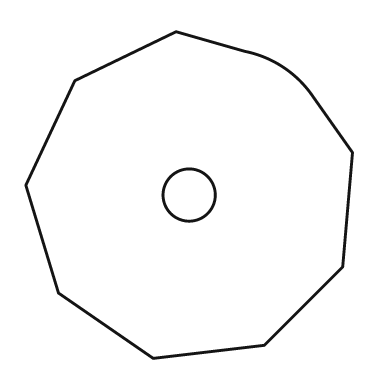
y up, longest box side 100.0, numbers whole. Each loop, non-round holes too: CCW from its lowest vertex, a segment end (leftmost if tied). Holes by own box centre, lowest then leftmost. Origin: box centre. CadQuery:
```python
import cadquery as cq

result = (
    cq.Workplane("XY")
    .moveTo(-11.0, -50.0)
    .lineTo(23.0, -46.0)
    .lineTo(47.0, -22.0)
    .lineTo(50.0, 13.0)
    .lineTo(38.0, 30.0)
    .threePointArc((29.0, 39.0), (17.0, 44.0))
    .lineTo(-4.0, 50.0)
    .lineTo(-35.0, 35.0)
    .lineTo(-50.0, 3.0)
    .lineTo(-40.0, -30.0)
    .close()
    .moveTo(0.0, 0.0)
    .circle(8.0)
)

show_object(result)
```